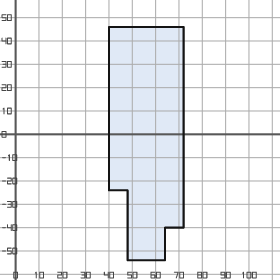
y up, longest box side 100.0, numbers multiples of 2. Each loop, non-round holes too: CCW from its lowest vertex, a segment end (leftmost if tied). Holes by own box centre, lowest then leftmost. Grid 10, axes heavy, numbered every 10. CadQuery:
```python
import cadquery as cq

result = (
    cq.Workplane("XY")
    .moveTo(48.0, -54.0)
    .lineTo(64.0, -54.0)
    .lineTo(64.0, -40.0)
    .lineTo(72.0, -40.0)
    .lineTo(72.0, 46.0)
    .lineTo(40.0, 46.0)
    .lineTo(40.0, -24.0)
    .lineTo(48.0, -24.0)
    .close()
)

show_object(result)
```